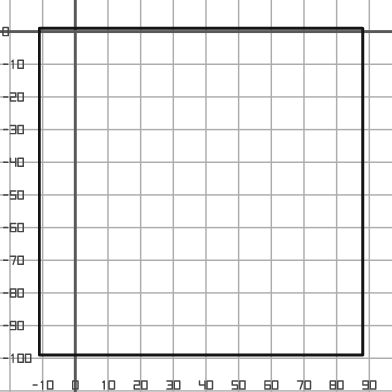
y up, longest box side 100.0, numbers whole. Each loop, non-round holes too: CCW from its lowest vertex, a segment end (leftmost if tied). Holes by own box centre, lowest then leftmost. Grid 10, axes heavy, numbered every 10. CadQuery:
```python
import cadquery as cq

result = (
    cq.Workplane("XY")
    .moveTo(-11.0, -99.0)
    .lineTo(88.0, -99.0)
    .lineTo(88.0, 1.0)
    .lineTo(-11.0, 1.0)
    .close()
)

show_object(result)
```